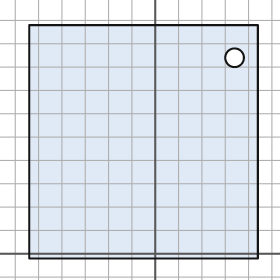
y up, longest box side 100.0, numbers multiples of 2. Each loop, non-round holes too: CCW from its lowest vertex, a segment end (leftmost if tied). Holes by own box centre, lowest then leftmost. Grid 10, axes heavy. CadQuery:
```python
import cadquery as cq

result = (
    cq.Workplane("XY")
    .moveTo(-54.0, -2.0)
    .lineTo(44.0, -2.0)
    .lineTo(44.0, 98.0)
    .lineTo(-54.0, 98.0)
    .close()
    .moveTo(34.0, 84.0)
    .circle(4.0)
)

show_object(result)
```